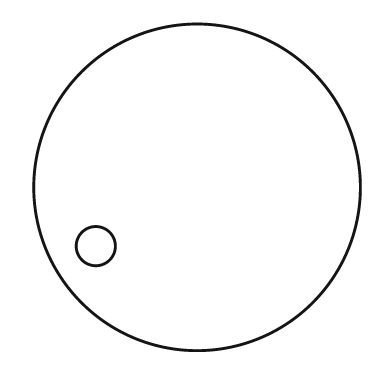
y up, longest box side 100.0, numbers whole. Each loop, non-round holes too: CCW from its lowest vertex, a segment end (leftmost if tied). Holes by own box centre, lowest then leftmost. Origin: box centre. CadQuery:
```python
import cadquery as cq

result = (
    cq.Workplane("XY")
    .moveTo(0.0, 0.0)
    .circle(50.0)
    .moveTo(-31.0, -18.0)
    .circle(6.0)
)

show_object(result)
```